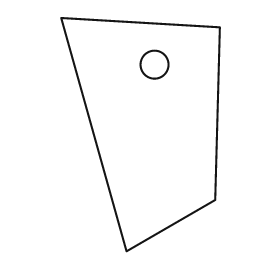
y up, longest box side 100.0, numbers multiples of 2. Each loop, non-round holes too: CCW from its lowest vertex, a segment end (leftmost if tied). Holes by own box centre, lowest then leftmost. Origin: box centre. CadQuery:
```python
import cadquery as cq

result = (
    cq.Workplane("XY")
    .moveTo(-6.0, -50.0)
    .lineTo(32.0, -28.0)
    .lineTo(34.0, 46.0)
    .lineTo(-34.0, 50.0)
    .close()
    .moveTo(6.0, 30.0)
    .circle(6.0)
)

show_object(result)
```